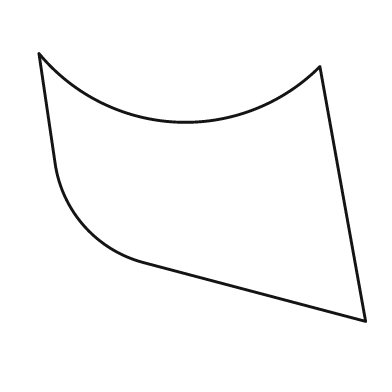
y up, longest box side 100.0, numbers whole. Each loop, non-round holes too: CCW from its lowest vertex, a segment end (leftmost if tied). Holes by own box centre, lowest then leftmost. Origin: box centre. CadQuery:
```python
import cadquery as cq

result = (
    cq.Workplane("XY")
    .moveTo(50.0, -41.0)
    .lineTo(36.0, 37.0)
    .threePointArc((-8.0, 20.0), (-50.0, 41.0))
    .lineTo(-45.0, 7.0)
    .threePointArc((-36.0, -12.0), (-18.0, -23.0))
    .close()
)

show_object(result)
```